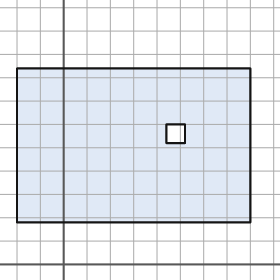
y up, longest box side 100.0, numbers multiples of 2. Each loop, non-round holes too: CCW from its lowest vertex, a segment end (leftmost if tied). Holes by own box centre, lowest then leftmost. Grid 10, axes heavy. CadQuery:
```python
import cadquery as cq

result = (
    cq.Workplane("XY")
    .moveTo(-20.0, 18.0)
    .lineTo(80.0, 18.0)
    .lineTo(80.0, 84.0)
    .lineTo(-20.0, 84.0)
    .close()
    .moveTo(44.0, 52.0)
    .lineTo(52.0, 52.0)
    .lineTo(52.0, 60.0)
    .lineTo(44.0, 60.0)
    .close()
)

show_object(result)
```